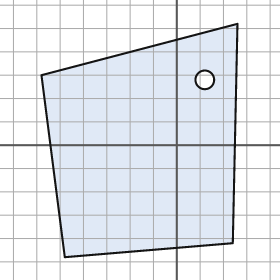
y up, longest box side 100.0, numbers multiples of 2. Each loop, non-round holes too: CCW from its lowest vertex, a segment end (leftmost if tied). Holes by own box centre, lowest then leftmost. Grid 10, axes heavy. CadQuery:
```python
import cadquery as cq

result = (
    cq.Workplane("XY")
    .moveTo(-48.0, -48.0)
    .lineTo(24.0, -42.0)
    .lineTo(26.0, 52.0)
    .lineTo(-58.0, 30.0)
    .close()
    .moveTo(12.0, 28.0)
    .circle(4.0)
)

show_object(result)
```